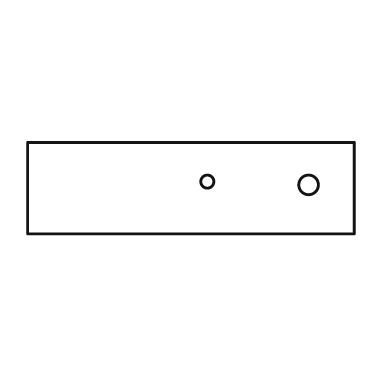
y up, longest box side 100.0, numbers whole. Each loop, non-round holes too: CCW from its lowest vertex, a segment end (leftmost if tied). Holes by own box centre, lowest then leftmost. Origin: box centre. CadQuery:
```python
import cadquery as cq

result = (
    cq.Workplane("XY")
    .moveTo(-50.0, -14.0)
    .lineTo(50.0, -14.0)
    .lineTo(50.0, 14.0)
    .lineTo(-50.0, 14.0)
    .close()
    .moveTo(36.0, 1.0)
    .circle(3.0)
    .moveTo(5.0, 2.0)
    .circle(2.0)
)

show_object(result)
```